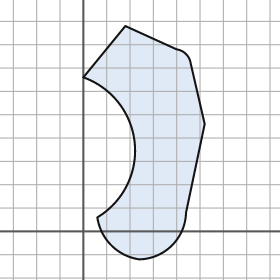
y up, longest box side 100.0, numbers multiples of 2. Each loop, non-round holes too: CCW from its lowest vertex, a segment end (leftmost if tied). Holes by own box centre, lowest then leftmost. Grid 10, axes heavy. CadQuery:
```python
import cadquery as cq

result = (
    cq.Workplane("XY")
    .moveTo(24.0, -12.0)
    .threePointArc((38.0, -6.0), (44.0, 8.0))
    .lineTo(52.0, 46.0)
    .lineTo(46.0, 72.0)
    .threePointArc((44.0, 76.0), (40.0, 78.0))
    .lineTo(18.0, 88.0)
    .lineTo(0.0, 66.0)
    .threePointArc((22.0, 38.0), (6.0, 6.0))
    .threePointArc((12.0, -6.0), (24.0, -12.0))
    .close()
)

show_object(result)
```